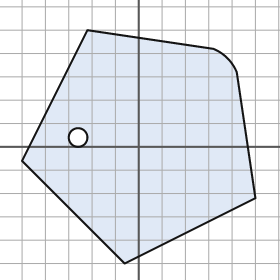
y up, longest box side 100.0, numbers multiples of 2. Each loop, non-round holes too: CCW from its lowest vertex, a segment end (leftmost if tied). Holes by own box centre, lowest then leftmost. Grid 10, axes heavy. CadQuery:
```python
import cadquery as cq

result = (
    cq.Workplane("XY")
    .moveTo(-6.0, -50.0)
    .lineTo(50.0, -22.0)
    .lineTo(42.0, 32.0)
    .threePointArc((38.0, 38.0), (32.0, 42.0))
    .lineTo(-22.0, 50.0)
    .lineTo(-50.0, -6.0)
    .close()
    .moveTo(-26.0, 4.0)
    .circle(4.0)
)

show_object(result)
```